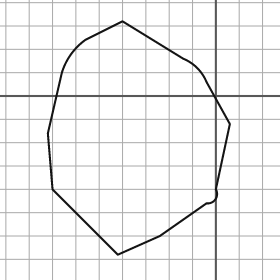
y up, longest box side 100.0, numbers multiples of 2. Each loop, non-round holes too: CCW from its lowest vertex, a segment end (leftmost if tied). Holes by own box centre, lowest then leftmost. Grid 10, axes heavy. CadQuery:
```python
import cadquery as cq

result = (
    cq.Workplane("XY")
    .moveTo(-42.0, -68.0)
    .lineTo(-24.0, -60.0)
    .lineTo(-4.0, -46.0)
    .threePointArc((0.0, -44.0), (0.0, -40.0))
    .lineTo(6.0, -12.0)
    .lineTo(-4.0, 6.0)
    .threePointArc((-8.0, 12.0), (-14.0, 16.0))
    .lineTo(-40.0, 32.0)
    .lineTo(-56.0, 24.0)
    .threePointArc((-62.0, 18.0), (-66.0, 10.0))
    .lineTo(-72.0, -16.0)
    .lineTo(-70.0, -40.0)
    .close()
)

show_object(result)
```